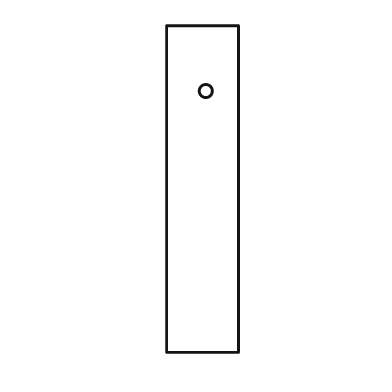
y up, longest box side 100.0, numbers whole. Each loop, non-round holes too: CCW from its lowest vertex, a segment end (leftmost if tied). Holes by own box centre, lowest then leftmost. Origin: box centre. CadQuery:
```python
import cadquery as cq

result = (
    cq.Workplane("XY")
    .moveTo(-11.0, -50.0)
    .lineTo(11.0, -50.0)
    .lineTo(11.0, 50.0)
    .lineTo(-11.0, 50.0)
    .close()
    .moveTo(1.0, 30.0)
    .circle(2.0)
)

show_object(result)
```